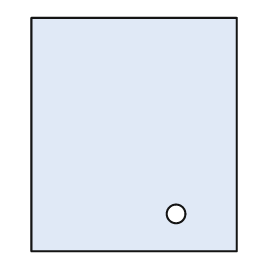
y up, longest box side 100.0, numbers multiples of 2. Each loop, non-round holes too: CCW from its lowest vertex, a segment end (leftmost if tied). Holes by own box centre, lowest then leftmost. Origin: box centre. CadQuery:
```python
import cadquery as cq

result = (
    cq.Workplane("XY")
    .moveTo(-44.0, -50.0)
    .lineTo(44.0, -50.0)
    .lineTo(44.0, 50.0)
    .lineTo(-44.0, 50.0)
    .close()
    .moveTo(18.0, -34.0)
    .circle(4.0)
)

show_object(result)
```